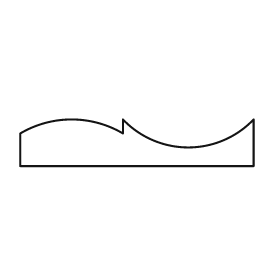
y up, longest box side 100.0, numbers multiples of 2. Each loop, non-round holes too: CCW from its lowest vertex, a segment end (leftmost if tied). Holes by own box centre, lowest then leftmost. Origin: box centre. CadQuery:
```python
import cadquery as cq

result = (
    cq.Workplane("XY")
    .moveTo(-50.0, -10.0)
    .lineTo(50.0, -10.0)
    .lineTo(50.0, 10.0)
    .threePointArc((22.0, -2.0), (-6.0, 10.0))
    .lineTo(-6.0, 4.0)
    .threePointArc((-28.0, 10.0), (-50.0, 4.0))
    .close()
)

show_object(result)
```